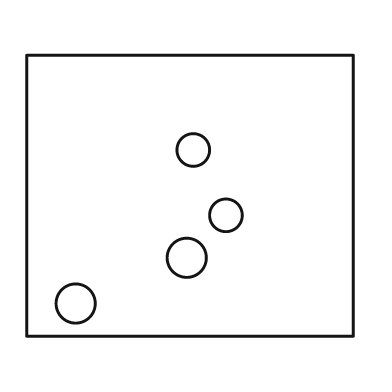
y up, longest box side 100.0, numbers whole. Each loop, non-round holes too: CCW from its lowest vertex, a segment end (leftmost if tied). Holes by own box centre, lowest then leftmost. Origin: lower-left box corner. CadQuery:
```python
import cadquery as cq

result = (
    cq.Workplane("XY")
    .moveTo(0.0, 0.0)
    .lineTo(100.0, 0.0)
    .lineTo(100.0, 86.0)
    .lineTo(0.0, 86.0)
    .close()
    .moveTo(15.0, 10.0)
    .circle(6.0)
    .moveTo(49.0, 24.0)
    .circle(6.0)
    .moveTo(61.0, 37.0)
    .circle(5.0)
    .moveTo(51.0, 57.0)
    .circle(5.0)
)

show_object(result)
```